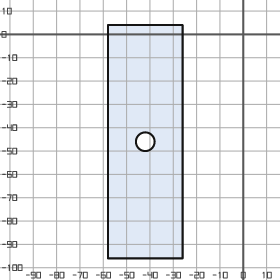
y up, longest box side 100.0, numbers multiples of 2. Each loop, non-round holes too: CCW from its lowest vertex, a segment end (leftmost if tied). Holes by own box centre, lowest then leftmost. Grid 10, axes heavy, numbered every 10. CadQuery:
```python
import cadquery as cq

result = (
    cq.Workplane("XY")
    .moveTo(-58.0, -96.0)
    .lineTo(-26.0, -96.0)
    .lineTo(-26.0, 4.0)
    .lineTo(-58.0, 4.0)
    .close()
    .moveTo(-42.0, -46.0)
    .circle(4.0)
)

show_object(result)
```